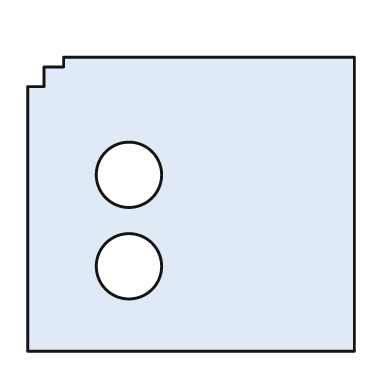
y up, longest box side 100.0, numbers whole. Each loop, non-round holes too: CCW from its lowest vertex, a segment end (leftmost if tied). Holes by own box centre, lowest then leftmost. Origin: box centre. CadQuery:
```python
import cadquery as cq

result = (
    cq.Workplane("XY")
    .moveTo(-50.0, -45.0)
    .lineTo(50.0, -45.0)
    .lineTo(50.0, 45.0)
    .lineTo(-39.0, 45.0)
    .lineTo(-39.0, 42.0)
    .lineTo(-45.0, 42.0)
    .lineTo(-45.0, 36.0)
    .lineTo(-50.0, 36.0)
    .close()
    .moveTo(-19.0, -19.0)
    .circle(10.0)
    .moveTo(-19.0, 9.0)
    .circle(10.0)
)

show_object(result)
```